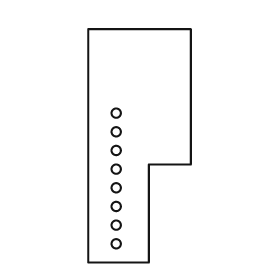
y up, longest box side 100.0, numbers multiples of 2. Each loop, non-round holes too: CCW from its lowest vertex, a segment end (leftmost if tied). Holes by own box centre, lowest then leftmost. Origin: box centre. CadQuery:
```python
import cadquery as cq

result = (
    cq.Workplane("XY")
    .moveTo(-22.0, -50.0)
    .lineTo(4.0, -50.0)
    .lineTo(4.0, -8.0)
    .lineTo(22.0, -8.0)
    .lineTo(22.0, 50.0)
    .lineTo(-22.0, 50.0)
    .close()
    .moveTo(-10.0, -42.0)
    .circle(2.0)
    .moveTo(-10.0, -34.0)
    .circle(2.0)
    .moveTo(-10.0, -26.0)
    .circle(2.0)
    .moveTo(-10.0, -18.0)
    .circle(2.0)
    .moveTo(-10.0, -10.0)
    .circle(2.0)
    .moveTo(-10.0, -2.0)
    .circle(2.0)
    .moveTo(-10.0, 6.0)
    .circle(2.0)
    .moveTo(-10.0, 14.0)
    .circle(2.0)
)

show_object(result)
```